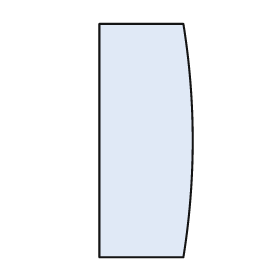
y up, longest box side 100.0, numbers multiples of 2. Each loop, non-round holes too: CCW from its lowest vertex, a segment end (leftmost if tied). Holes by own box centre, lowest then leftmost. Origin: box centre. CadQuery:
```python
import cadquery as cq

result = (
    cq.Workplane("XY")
    .moveTo(-20.0, -50.0)
    .lineTo(16.0, -50.0)
    .threePointArc((20.0, 0.0), (16.0, 50.0))
    .lineTo(-20.0, 50.0)
    .close()
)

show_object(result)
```